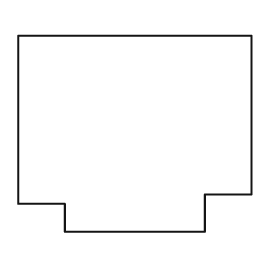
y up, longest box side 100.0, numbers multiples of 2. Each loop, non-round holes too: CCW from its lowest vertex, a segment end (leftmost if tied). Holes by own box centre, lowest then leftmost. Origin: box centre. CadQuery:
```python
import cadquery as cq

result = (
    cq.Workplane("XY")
    .moveTo(-30.0, -42.0)
    .lineTo(30.0, -42.0)
    .lineTo(30.0, -26.0)
    .lineTo(50.0, -26.0)
    .lineTo(50.0, 42.0)
    .lineTo(-50.0, 42.0)
    .lineTo(-50.0, -30.0)
    .lineTo(-30.0, -30.0)
    .close()
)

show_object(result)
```